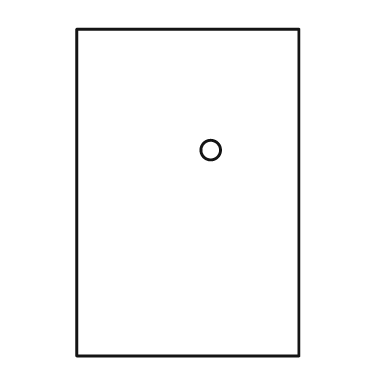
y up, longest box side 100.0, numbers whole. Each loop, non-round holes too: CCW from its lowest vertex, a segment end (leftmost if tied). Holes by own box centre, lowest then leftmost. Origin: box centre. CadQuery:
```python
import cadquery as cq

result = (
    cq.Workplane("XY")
    .moveTo(-34.0, -50.0)
    .lineTo(34.0, -50.0)
    .lineTo(34.0, 50.0)
    .lineTo(-34.0, 50.0)
    .close()
    .moveTo(7.0, 13.0)
    .circle(3.0)
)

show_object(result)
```